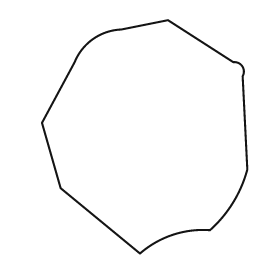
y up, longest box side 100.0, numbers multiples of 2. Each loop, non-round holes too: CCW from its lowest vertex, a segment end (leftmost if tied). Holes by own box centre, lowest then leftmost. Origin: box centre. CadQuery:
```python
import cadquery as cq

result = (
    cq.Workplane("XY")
    .moveTo(-2.0, -50.0)
    .threePointArc((12.0, -42.0), (28.0, -40.0))
    .threePointArc((38.0, -28.0), (44.0, -14.0))
    .lineTo(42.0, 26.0)
    .threePointArc((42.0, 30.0), (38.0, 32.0))
    .lineTo(10.0, 50.0)
    .lineTo(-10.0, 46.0)
    .threePointArc((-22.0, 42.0), (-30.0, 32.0))
    .lineTo(-44.0, 6.0)
    .lineTo(-36.0, -22.0)
    .close()
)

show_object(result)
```